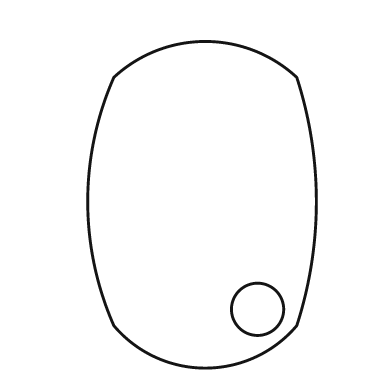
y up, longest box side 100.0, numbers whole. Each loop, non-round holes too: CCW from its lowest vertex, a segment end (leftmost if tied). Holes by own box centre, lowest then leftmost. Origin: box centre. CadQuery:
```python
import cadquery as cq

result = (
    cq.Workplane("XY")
    .moveTo(-27.0, -37.0)
    .threePointArc((1.0, -50.0), (29.0, -37.0))
    .threePointArc((35.0, 1.0), (29.0, 39.0))
    .threePointArc((1.0, 50.0), (-27.0, 39.0))
    .threePointArc((-35.0, 1.0), (-27.0, -37.0))
    .close()
    .moveTo(17.0, -32.0)
    .circle(8.0)
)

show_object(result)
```